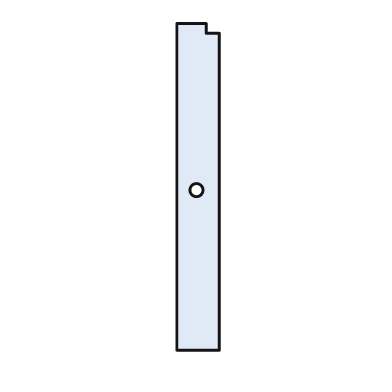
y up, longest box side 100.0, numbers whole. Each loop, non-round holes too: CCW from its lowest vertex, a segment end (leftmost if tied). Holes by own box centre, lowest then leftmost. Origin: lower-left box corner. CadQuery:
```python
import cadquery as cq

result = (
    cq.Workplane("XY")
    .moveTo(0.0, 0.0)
    .lineTo(13.0, 0.0)
    .lineTo(13.0, 97.0)
    .lineTo(9.0, 97.0)
    .lineTo(9.0, 100.0)
    .lineTo(0.0, 100.0)
    .close()
    .moveTo(6.0, 49.0)
    .circle(2.0)
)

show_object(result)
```